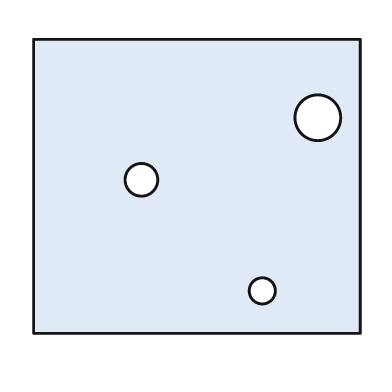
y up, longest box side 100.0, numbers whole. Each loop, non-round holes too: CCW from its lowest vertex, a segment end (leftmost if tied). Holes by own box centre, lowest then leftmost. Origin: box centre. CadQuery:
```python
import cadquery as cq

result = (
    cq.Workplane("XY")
    .moveTo(-50.0, -45.0)
    .lineTo(50.0, -45.0)
    .lineTo(50.0, 45.0)
    .lineTo(-50.0, 45.0)
    .close()
    .moveTo(20.0, -32.0)
    .circle(4.0)
    .moveTo(-17.0, 2.0)
    .circle(5.0)
    .moveTo(37.0, 21.0)
    .circle(7.0)
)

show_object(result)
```